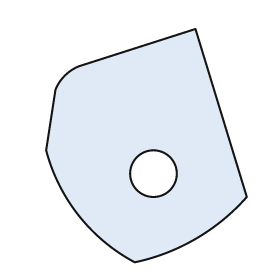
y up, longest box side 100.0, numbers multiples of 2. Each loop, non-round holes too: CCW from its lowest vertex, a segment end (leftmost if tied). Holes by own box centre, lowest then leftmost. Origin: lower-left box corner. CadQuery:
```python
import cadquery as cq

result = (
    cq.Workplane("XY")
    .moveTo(38.0, 0.0)
    .threePointArc((64.0, 10.0), (86.0, 28.0))
    .lineTo(64.0, 100.0)
    .lineTo(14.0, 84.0)
    .threePointArc((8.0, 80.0), (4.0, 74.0))
    .lineTo(0.0, 48.0)
    .threePointArc((14.0, 20.0), (38.0, 0.0))
    .close()
    .moveTo(46.0, 38.0)
    .circle(10.0)
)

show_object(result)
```